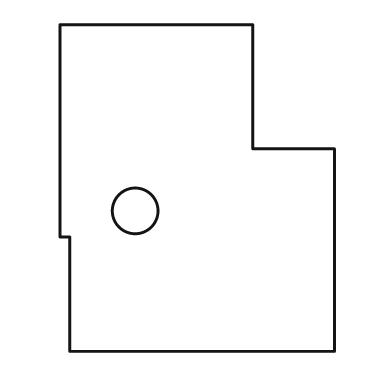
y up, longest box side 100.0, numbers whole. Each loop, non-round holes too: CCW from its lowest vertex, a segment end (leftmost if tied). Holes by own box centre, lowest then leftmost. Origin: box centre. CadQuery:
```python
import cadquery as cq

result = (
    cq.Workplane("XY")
    .moveTo(-39.0, -50.0)
    .lineTo(42.0, -50.0)
    .lineTo(42.0, 12.0)
    .lineTo(17.0, 12.0)
    .lineTo(17.0, 50.0)
    .lineTo(-42.0, 50.0)
    .lineTo(-42.0, -15.0)
    .lineTo(-39.0, -15.0)
    .close()
    .moveTo(-19.0, -7.0)
    .circle(7.0)
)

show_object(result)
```